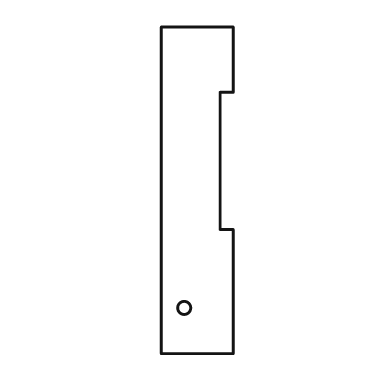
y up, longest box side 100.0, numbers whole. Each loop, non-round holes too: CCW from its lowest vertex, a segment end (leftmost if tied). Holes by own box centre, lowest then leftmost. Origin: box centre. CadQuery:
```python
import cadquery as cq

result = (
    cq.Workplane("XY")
    .moveTo(-11.0, -50.0)
    .lineTo(11.0, -50.0)
    .lineTo(11.0, -12.0)
    .lineTo(7.0, -12.0)
    .lineTo(7.0, 30.0)
    .lineTo(11.0, 30.0)
    .lineTo(11.0, 50.0)
    .lineTo(-11.0, 50.0)
    .close()
    .moveTo(-4.0, -36.0)
    .circle(2.0)
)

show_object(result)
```